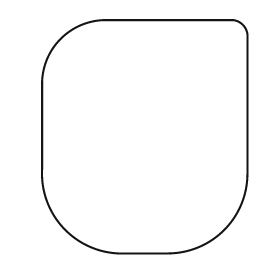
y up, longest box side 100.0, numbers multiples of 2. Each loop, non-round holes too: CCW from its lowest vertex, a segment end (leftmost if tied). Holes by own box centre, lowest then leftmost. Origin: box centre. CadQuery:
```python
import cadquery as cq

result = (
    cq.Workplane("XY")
    .moveTo(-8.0, -50.0)
    .lineTo(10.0, -50.0)
    .threePointArc((34.0, -40.0), (44.0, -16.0))
    .lineTo(44.0, 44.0)
    .threePointArc((42.0, 48.0), (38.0, 50.0))
    .lineTo(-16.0, 50.0)
    .threePointArc((-36.0, 42.0), (-44.0, 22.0))
    .lineTo(-44.0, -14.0)
    .threePointArc((-34.0, -40.0), (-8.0, -50.0))
    .close()
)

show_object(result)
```